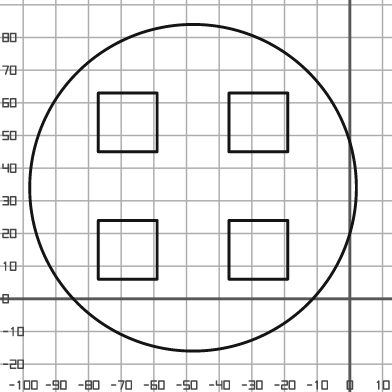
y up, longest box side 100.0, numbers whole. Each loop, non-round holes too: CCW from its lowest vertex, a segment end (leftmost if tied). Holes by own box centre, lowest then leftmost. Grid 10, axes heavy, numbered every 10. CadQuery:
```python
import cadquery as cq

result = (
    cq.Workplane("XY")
    .moveTo(-48.0, 34.0)
    .circle(50.0)
    .moveTo(-77.0, 6.0)
    .lineTo(-59.0, 6.0)
    .lineTo(-59.0, 24.0)
    .lineTo(-77.0, 24.0)
    .close()
    .moveTo(-37.0, 6.0)
    .lineTo(-19.0, 6.0)
    .lineTo(-19.0, 24.0)
    .lineTo(-37.0, 24.0)
    .close()
    .moveTo(-77.0, 45.0)
    .lineTo(-59.0, 45.0)
    .lineTo(-59.0, 63.0)
    .lineTo(-77.0, 63.0)
    .close()
    .moveTo(-37.0, 45.0)
    .lineTo(-19.0, 45.0)
    .lineTo(-19.0, 63.0)
    .lineTo(-37.0, 63.0)
    .close()
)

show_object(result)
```